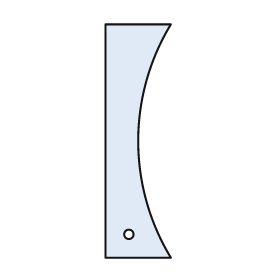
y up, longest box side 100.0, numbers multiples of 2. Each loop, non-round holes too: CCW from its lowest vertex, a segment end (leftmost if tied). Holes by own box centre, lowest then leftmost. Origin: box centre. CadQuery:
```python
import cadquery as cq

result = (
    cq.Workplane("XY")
    .moveTo(-14.0, -50.0)
    .lineTo(14.0, -50.0)
    .threePointArc((0.0, 0.0), (14.0, 50.0))
    .lineTo(-14.0, 50.0)
    .close()
    .moveTo(-4.0, -40.0)
    .circle(2.0)
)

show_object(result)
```